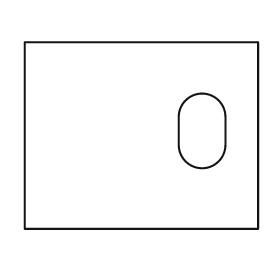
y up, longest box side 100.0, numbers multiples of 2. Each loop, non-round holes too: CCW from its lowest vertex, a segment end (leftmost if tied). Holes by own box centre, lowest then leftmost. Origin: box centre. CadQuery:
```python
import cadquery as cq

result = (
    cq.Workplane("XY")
    .moveTo(-50.0, -40.0)
    .lineTo(50.0, -40.0)
    .lineTo(50.0, 40.0)
    .lineTo(-50.0, 40.0)
    .close()
    .moveTo(16.0, -4.0)
    .threePointArc((26.0, -14.0), (36.0, -4.0))
    .lineTo(36.0, 8.0)
    .threePointArc((26.0, 18.0), (16.0, 8.0))
    .close()
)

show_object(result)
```